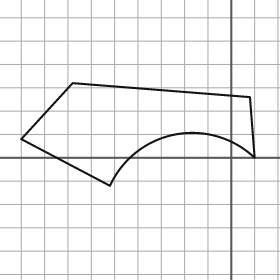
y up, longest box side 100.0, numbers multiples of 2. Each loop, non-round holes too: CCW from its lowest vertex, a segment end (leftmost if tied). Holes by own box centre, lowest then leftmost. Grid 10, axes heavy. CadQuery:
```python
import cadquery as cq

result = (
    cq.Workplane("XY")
    .moveTo(-52.0, -12.0)
    .threePointArc((-24.0, 10.0), (10.0, 0.0))
    .lineTo(8.0, 26.0)
    .lineTo(-68.0, 32.0)
    .lineTo(-90.0, 8.0)
    .close()
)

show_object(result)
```